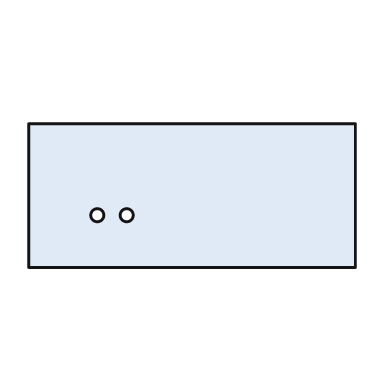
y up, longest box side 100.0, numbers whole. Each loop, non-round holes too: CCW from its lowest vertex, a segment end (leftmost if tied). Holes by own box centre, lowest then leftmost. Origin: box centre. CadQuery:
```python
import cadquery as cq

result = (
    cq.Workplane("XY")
    .moveTo(-50.0, -22.0)
    .lineTo(50.0, -22.0)
    .lineTo(50.0, 22.0)
    .lineTo(-50.0, 22.0)
    .close()
    .moveTo(-29.0, -6.0)
    .circle(2.0)
    .moveTo(-20.0, -6.0)
    .circle(2.0)
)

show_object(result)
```